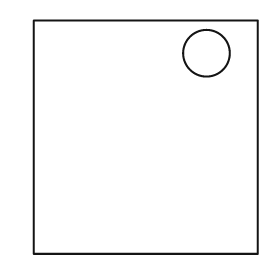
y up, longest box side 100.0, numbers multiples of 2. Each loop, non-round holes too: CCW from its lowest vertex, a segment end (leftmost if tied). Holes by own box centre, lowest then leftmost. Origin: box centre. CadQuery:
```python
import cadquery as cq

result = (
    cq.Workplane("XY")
    .moveTo(-48.0, -50.0)
    .lineTo(48.0, -50.0)
    .lineTo(48.0, 50.0)
    .lineTo(-48.0, 50.0)
    .close()
    .moveTo(26.0, 36.0)
    .circle(10.0)
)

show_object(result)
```